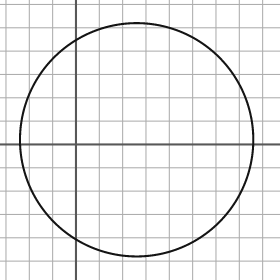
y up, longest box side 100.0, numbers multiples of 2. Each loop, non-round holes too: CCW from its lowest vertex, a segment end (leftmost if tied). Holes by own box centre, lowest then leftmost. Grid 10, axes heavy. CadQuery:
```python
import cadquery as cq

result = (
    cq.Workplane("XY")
    .moveTo(26.0, 2.0)
    .circle(50.0)
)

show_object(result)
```